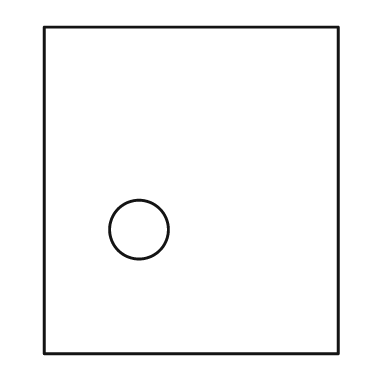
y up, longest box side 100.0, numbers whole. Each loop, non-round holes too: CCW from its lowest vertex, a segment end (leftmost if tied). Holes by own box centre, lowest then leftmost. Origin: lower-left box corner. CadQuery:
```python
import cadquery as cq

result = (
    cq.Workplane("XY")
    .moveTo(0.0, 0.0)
    .lineTo(90.0, 0.0)
    .lineTo(90.0, 100.0)
    .lineTo(0.0, 100.0)
    .close()
    .moveTo(29.0, 38.0)
    .circle(9.0)
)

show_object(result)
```